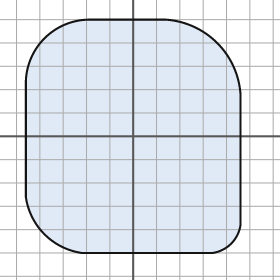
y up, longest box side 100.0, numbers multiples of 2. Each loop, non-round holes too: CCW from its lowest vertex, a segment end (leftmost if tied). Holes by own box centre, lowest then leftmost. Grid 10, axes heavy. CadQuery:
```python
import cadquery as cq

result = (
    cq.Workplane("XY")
    .moveTo(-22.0, -50.0)
    .lineTo(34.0, -50.0)
    .threePointArc((42.0, -46.0), (46.0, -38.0))
    .lineTo(46.0, 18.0)
    .threePointArc((36.0, 40.0), (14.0, 50.0))
    .lineTo(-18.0, 50.0)
    .threePointArc((-38.0, 42.0), (-46.0, 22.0))
    .lineTo(-46.0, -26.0)
    .threePointArc((-38.0, -42.0), (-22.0, -50.0))
    .close()
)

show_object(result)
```